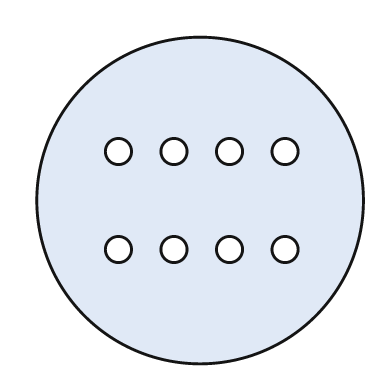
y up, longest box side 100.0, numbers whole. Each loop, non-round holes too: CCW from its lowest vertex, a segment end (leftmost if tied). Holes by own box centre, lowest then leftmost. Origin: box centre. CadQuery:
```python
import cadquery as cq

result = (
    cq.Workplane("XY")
    .moveTo(0.0, 0.0)
    .circle(50.0)
    .moveTo(-25.0, -15.0)
    .circle(4.0)
    .moveTo(-8.0, -15.0)
    .circle(4.0)
    .moveTo(9.0, -15.0)
    .circle(4.0)
    .moveTo(26.0, -15.0)
    .circle(4.0)
    .moveTo(-25.0, 15.0)
    .circle(4.0)
    .moveTo(-8.0, 15.0)
    .circle(4.0)
    .moveTo(9.0, 15.0)
    .circle(4.0)
    .moveTo(26.0, 15.0)
    .circle(4.0)
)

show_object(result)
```